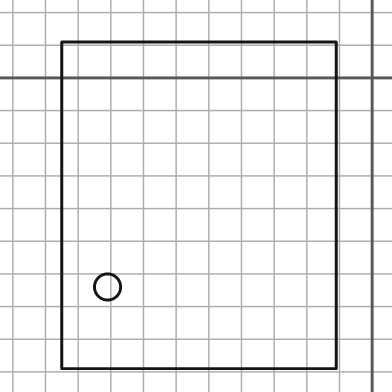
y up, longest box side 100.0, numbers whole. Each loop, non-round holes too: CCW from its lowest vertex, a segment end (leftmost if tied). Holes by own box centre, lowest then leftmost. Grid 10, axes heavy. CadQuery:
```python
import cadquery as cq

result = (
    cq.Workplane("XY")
    .moveTo(-95.0, -89.0)
    .lineTo(-11.0, -89.0)
    .lineTo(-11.0, 11.0)
    .lineTo(-95.0, 11.0)
    .close()
    .moveTo(-81.0, -64.0)
    .circle(4.0)
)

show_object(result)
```